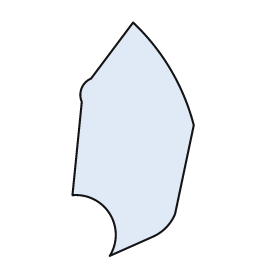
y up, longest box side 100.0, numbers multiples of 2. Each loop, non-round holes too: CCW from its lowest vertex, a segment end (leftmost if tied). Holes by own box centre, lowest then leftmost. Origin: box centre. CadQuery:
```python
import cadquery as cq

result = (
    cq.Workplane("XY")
    .moveTo(-10.0, -50.0)
    .lineTo(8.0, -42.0)
    .threePointArc((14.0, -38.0), (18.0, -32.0))
    .lineTo(26.0, 6.0)
    .threePointArc((16.0, 30.0), (0.0, 50.0))
    .lineTo(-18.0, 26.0)
    .threePointArc((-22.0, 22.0), (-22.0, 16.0))
    .lineTo(-26.0, -24.0)
    .threePointArc((-10.0, -32.0), (-10.0, -50.0))
    .close()
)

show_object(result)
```